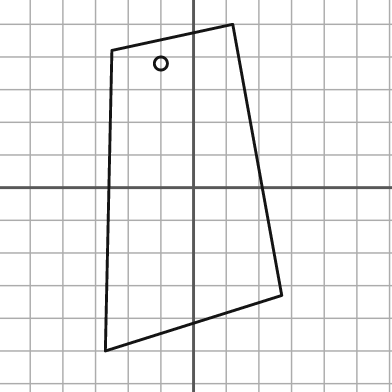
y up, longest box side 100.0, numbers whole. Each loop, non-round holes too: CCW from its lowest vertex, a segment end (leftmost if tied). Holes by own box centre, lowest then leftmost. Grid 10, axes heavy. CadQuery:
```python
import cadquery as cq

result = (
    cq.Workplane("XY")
    .moveTo(-27.0, -50.0)
    .lineTo(27.0, -33.0)
    .lineTo(12.0, 50.0)
    .lineTo(-25.0, 42.0)
    .close()
    .moveTo(-10.0, 38.0)
    .circle(2.0)
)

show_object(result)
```